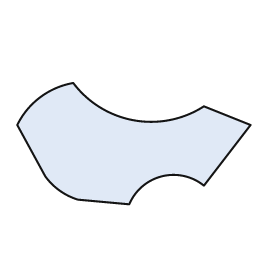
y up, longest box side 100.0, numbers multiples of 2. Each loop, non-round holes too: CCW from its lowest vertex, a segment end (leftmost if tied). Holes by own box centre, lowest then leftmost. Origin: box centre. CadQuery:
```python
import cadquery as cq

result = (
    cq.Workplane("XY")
    .moveTo(-2.0, -26.0)
    .threePointArc((12.0, -14.0), (30.0, -18.0))
    .lineTo(50.0, 8.0)
    .lineTo(30.0, 16.0)
    .threePointArc((0.0, 10.0), (-26.0, 26.0))
    .threePointArc((-40.0, 20.0), (-50.0, 8.0))
    .lineTo(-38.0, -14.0)
    .threePointArc((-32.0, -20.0), (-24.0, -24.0))
    .close()
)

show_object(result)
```